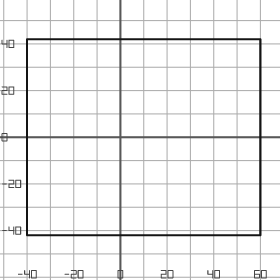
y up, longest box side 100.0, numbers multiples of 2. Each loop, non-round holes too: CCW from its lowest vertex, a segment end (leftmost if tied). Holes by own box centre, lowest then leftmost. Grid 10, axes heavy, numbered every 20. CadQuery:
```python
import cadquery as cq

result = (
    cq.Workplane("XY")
    .moveTo(-40.0, -42.0)
    .lineTo(60.0, -42.0)
    .lineTo(60.0, 42.0)
    .lineTo(-40.0, 42.0)
    .close()
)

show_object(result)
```